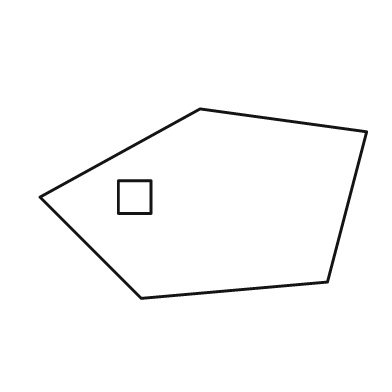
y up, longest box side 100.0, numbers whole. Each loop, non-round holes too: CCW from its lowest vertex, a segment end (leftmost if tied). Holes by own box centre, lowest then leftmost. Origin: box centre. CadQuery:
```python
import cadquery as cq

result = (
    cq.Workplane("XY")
    .moveTo(-19.0, -29.0)
    .lineTo(38.0, -24.0)
    .lineTo(50.0, 22.0)
    .lineTo(-1.0, 29.0)
    .lineTo(-50.0, 2.0)
    .close()
    .moveTo(-26.0, -3.0)
    .lineTo(-16.0, -3.0)
    .lineTo(-16.0, 7.0)
    .lineTo(-26.0, 7.0)
    .close()
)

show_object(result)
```